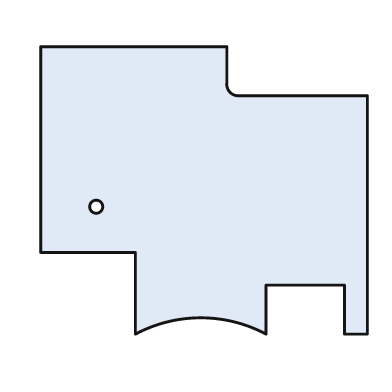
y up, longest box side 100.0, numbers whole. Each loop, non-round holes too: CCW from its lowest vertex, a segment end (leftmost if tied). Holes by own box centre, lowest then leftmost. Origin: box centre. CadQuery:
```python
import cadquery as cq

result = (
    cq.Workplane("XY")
    .moveTo(-21.0, -44.0)
    .threePointArc((-1.0, -39.0), (19.0, -44.0))
    .lineTo(19.0, -29.0)
    .lineTo(43.0, -29.0)
    .lineTo(43.0, -44.0)
    .lineTo(50.0, -44.0)
    .lineTo(50.0, 29.0)
    .lineTo(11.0, 29.0)
    .threePointArc((8.0, 30.0), (7.0, 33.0))
    .lineTo(7.0, 44.0)
    .lineTo(-50.0, 44.0)
    .lineTo(-50.0, -19.0)
    .lineTo(-21.0, -19.0)
    .close()
    .moveTo(-33.0, -5.0)
    .circle(2.0)
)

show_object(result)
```